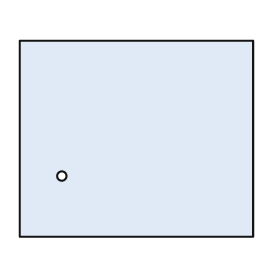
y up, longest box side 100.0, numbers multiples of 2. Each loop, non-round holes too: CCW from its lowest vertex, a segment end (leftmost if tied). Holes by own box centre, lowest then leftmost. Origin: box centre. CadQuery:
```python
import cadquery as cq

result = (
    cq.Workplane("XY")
    .moveTo(-50.0, -42.0)
    .lineTo(50.0, -42.0)
    .lineTo(50.0, 42.0)
    .lineTo(-50.0, 42.0)
    .close()
    .moveTo(-32.0, -16.0)
    .circle(2.0)
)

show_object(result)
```